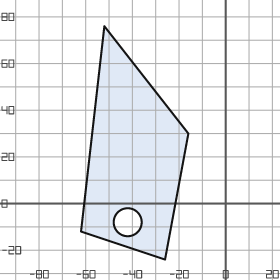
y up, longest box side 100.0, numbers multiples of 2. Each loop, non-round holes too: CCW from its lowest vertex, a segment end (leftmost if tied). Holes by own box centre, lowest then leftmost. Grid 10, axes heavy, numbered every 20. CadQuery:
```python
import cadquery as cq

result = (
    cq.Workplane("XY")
    .moveTo(-26.0, -24.0)
    .lineTo(-16.0, 30.0)
    .lineTo(-52.0, 76.0)
    .lineTo(-62.0, -12.0)
    .close()
    .moveTo(-42.0, -8.0)
    .circle(6.0)
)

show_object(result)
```